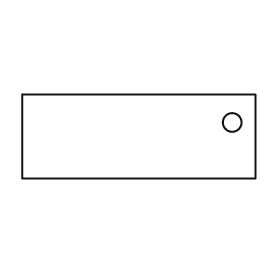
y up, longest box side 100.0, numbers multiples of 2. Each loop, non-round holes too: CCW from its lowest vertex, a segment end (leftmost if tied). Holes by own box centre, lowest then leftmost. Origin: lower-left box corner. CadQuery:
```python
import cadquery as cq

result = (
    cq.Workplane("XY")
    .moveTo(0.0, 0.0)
    .lineTo(100.0, 0.0)
    .lineTo(100.0, 36.0)
    .lineTo(0.0, 36.0)
    .close()
    .moveTo(90.0, 24.0)
    .circle(4.0)
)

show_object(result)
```